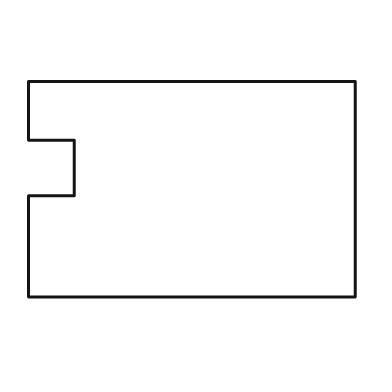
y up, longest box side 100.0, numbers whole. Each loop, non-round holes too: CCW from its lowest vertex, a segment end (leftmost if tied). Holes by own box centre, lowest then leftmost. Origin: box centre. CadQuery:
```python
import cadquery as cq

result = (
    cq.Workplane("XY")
    .moveTo(-50.0, -33.0)
    .lineTo(50.0, -33.0)
    .lineTo(50.0, 33.0)
    .lineTo(-50.0, 33.0)
    .lineTo(-50.0, 15.0)
    .lineTo(-36.0, 15.0)
    .lineTo(-36.0, -2.0)
    .lineTo(-50.0, -2.0)
    .close()
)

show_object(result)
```